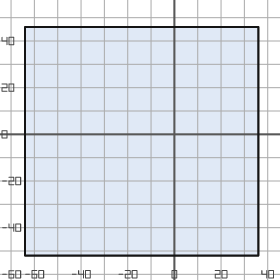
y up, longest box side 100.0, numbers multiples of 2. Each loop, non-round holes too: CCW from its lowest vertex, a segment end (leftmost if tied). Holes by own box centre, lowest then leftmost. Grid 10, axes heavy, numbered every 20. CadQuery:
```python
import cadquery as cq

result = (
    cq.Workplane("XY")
    .moveTo(-64.0, -52.0)
    .lineTo(36.0, -52.0)
    .lineTo(36.0, 46.0)
    .lineTo(-64.0, 46.0)
    .close()
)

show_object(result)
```